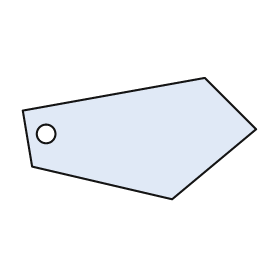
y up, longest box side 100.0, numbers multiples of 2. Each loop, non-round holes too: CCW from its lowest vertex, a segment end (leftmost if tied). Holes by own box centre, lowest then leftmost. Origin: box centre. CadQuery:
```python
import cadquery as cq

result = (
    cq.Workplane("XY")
    .moveTo(14.0, -26.0)
    .lineTo(50.0, 4.0)
    .lineTo(28.0, 26.0)
    .lineTo(-50.0, 12.0)
    .lineTo(-46.0, -12.0)
    .close()
    .moveTo(-40.0, 2.0)
    .circle(4.0)
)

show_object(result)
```